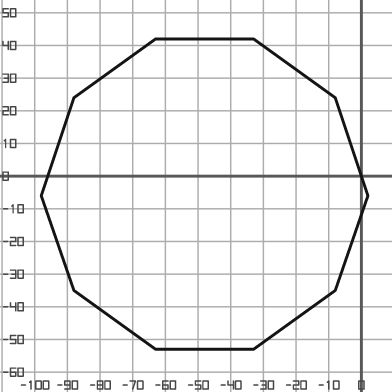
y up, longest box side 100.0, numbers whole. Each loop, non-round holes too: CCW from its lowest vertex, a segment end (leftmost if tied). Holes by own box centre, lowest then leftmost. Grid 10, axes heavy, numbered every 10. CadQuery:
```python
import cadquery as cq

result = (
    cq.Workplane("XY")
    .moveTo(-63.0, -53.0)
    .lineTo(-33.0, -53.0)
    .lineTo(-8.0, -35.0)
    .lineTo(2.0, -6.0)
    .lineTo(-8.0, 24.0)
    .lineTo(-33.0, 42.0)
    .lineTo(-63.0, 42.0)
    .lineTo(-88.0, 24.0)
    .lineTo(-98.0, -6.0)
    .lineTo(-88.0, -35.0)
    .close()
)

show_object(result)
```